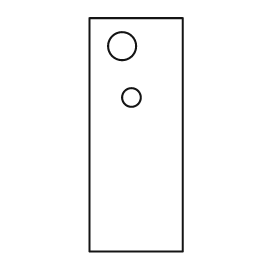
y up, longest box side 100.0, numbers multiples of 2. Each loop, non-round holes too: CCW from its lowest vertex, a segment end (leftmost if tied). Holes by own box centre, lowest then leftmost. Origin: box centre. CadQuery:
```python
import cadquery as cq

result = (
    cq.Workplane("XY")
    .moveTo(-20.0, -50.0)
    .lineTo(20.0, -50.0)
    .lineTo(20.0, 50.0)
    .lineTo(-20.0, 50.0)
    .close()
    .moveTo(-2.0, 16.0)
    .circle(4.0)
    .moveTo(-6.0, 38.0)
    .circle(6.0)
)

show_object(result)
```